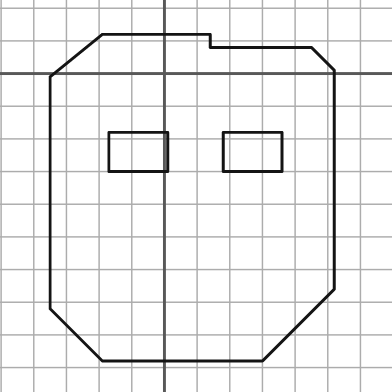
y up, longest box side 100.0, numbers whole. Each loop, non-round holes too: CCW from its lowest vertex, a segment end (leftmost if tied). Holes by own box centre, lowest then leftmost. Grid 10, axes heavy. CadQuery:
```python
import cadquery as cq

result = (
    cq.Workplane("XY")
    .moveTo(-19.0, -88.0)
    .lineTo(30.0, -88.0)
    .lineTo(52.0, -66.0)
    .lineTo(52.0, 1.0)
    .lineTo(45.0, 8.0)
    .lineTo(14.0, 8.0)
    .lineTo(14.0, 12.0)
    .lineTo(-19.0, 12.0)
    .lineTo(-35.0, -1.0)
    .lineTo(-35.0, -72.0)
    .close()
    .moveTo(-17.0, -30.0)
    .lineTo(1.0, -30.0)
    .lineTo(1.0, -18.0)
    .lineTo(-17.0, -18.0)
    .close()
    .moveTo(18.0, -30.0)
    .lineTo(36.0, -30.0)
    .lineTo(36.0, -18.0)
    .lineTo(18.0, -18.0)
    .close()
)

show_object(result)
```